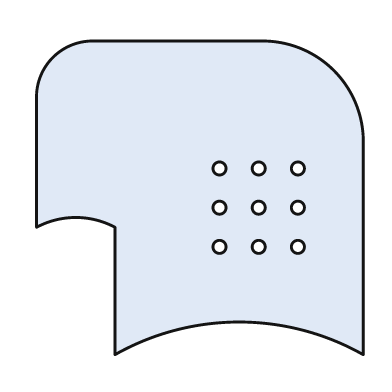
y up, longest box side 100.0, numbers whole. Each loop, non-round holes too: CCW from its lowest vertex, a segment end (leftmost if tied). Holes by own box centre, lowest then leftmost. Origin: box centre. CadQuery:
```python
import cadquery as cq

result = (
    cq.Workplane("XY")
    .moveTo(-26.0, -48.0)
    .threePointArc((12.0, -38.0), (50.0, -48.0))
    .lineTo(50.0, 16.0)
    .threePointArc((41.0, 39.0), (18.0, 48.0))
    .lineTo(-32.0, 48.0)
    .threePointArc((-45.0, 43.0), (-50.0, 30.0))
    .lineTo(-50.0, -9.0)
    .threePointArc((-38.0, -6.0), (-26.0, -9.0))
    .close()
    .moveTo(6.0, -15.0)
    .circle(2.0)
    .moveTo(18.0, -15.0)
    .circle(2.0)
    .moveTo(30.0, -15.0)
    .circle(2.0)
    .moveTo(6.0, -3.0)
    .circle(2.0)
    .moveTo(18.0, -3.0)
    .circle(2.0)
    .moveTo(30.0, -3.0)
    .circle(2.0)
    .moveTo(6.0, 9.0)
    .circle(2.0)
    .moveTo(18.0, 9.0)
    .circle(2.0)
    .moveTo(30.0, 9.0)
    .circle(2.0)
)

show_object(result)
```